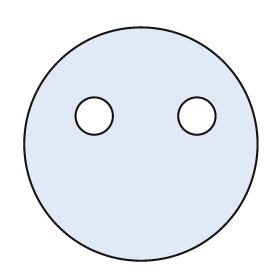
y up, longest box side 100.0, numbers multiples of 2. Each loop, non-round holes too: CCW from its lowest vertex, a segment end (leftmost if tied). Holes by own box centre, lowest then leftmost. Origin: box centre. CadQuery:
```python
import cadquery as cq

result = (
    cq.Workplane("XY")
    .moveTo(0.0, 0.0)
    .circle(50.0)
    .moveTo(-20.0, 12.0)
    .circle(8.0)
    .moveTo(24.0, 12.0)
    .circle(8.0)
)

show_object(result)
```